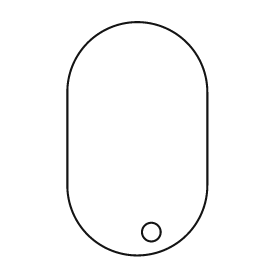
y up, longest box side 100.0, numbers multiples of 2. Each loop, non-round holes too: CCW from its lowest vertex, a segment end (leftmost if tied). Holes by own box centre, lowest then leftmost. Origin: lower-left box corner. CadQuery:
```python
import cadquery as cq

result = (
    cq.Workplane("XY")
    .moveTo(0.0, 30.0)
    .threePointArc((30.0, 0.0), (60.0, 30.0))
    .lineTo(60.0, 70.0)
    .threePointArc((30.0, 100.0), (0.0, 70.0))
    .close()
    .moveTo(36.0, 10.0)
    .circle(4.0)
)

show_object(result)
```